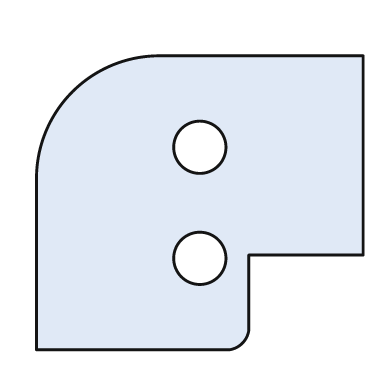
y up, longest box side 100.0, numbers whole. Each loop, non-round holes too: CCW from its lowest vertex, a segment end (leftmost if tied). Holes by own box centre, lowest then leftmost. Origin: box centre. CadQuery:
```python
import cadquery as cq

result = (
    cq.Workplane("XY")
    .moveTo(-50.0, -45.0)
    .lineTo(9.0, -45.0)
    .threePointArc((13.0, -43.0), (15.0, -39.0))
    .lineTo(15.0, -16.0)
    .lineTo(50.0, -16.0)
    .lineTo(50.0, 45.0)
    .lineTo(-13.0, 45.0)
    .threePointArc((-39.0, 34.0), (-50.0, 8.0))
    .close()
    .moveTo(0.0, -17.0)
    .circle(8.0)
    .moveTo(0.0, 17.0)
    .circle(8.0)
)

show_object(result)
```